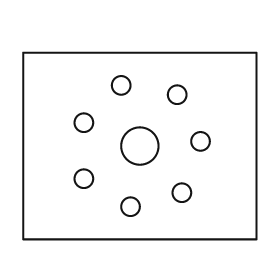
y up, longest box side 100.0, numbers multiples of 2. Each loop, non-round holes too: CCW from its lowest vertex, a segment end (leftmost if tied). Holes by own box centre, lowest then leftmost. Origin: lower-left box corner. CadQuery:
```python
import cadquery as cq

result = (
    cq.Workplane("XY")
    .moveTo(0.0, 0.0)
    .lineTo(100.0, 0.0)
    .lineTo(100.0, 80.0)
    .lineTo(0.0, 80.0)
    .close()
    .moveTo(46.0, 14.0)
    .circle(4.0)
    .moveTo(68.0, 20.0)
    .circle(4.0)
    .moveTo(26.0, 26.0)
    .circle(4.0)
    .moveTo(50.0, 40.0)
    .circle(8.0)
    .moveTo(76.0, 42.0)
    .circle(4.0)
    .moveTo(26.0, 50.0)
    .circle(4.0)
    .moveTo(66.0, 62.0)
    .circle(4.0)
    .moveTo(42.0, 66.0)
    .circle(4.0)
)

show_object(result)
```